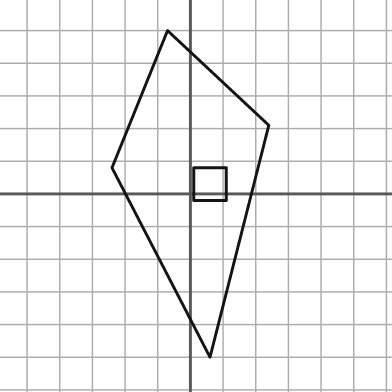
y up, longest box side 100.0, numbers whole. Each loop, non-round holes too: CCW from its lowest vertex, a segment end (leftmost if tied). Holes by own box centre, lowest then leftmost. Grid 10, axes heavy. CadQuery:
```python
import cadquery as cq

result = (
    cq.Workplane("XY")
    .moveTo(6.0, -50.0)
    .lineTo(24.0, 21.0)
    .lineTo(-7.0, 50.0)
    .lineTo(-24.0, 8.0)
    .close()
    .moveTo(1.0, -2.0)
    .lineTo(11.0, -2.0)
    .lineTo(11.0, 8.0)
    .lineTo(1.0, 8.0)
    .close()
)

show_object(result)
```